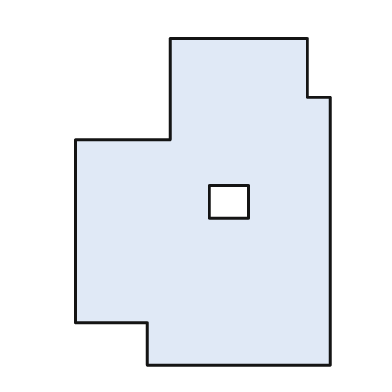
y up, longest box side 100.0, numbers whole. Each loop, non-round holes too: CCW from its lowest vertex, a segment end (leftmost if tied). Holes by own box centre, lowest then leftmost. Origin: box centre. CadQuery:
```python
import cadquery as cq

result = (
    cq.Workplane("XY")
    .moveTo(-17.0, -50.0)
    .lineTo(39.0, -50.0)
    .lineTo(39.0, 32.0)
    .lineTo(32.0, 32.0)
    .lineTo(32.0, 50.0)
    .lineTo(-10.0, 50.0)
    .lineTo(-10.0, 19.0)
    .lineTo(-39.0, 19.0)
    .lineTo(-39.0, -37.0)
    .lineTo(-17.0, -37.0)
    .close()
    .moveTo(2.0, -5.0)
    .lineTo(14.0, -5.0)
    .lineTo(14.0, 5.0)
    .lineTo(2.0, 5.0)
    .close()
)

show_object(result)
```